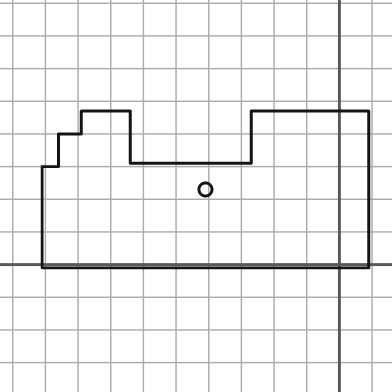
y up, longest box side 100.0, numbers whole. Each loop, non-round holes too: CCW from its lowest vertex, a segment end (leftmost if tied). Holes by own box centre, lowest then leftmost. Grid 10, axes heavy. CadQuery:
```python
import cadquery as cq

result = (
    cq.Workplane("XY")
    .moveTo(-91.0, -1.0)
    .lineTo(9.0, -1.0)
    .lineTo(9.0, 47.0)
    .lineTo(-27.0, 47.0)
    .lineTo(-27.0, 31.0)
    .lineTo(-64.0, 31.0)
    .lineTo(-64.0, 47.0)
    .lineTo(-79.0, 47.0)
    .lineTo(-79.0, 40.0)
    .lineTo(-86.0, 40.0)
    .lineTo(-86.0, 30.0)
    .lineTo(-91.0, 30.0)
    .close()
    .moveTo(-41.0, 23.0)
    .circle(2.0)
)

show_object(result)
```